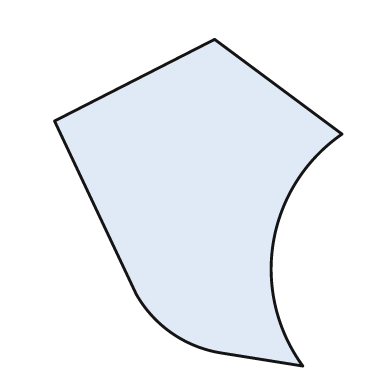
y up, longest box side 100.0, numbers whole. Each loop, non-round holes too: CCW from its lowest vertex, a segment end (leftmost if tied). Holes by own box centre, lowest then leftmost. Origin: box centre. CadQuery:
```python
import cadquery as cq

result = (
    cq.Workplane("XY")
    .moveTo(32.0, -50.0)
    .threePointArc((23.0, -12.0), (44.0, 21.0))
    .lineTo(5.0, 50.0)
    .lineTo(-44.0, 25.0)
    .lineTo(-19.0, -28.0)
    .threePointArc((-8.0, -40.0), (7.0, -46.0))
    .close()
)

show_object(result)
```